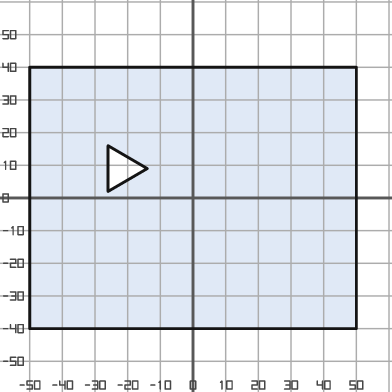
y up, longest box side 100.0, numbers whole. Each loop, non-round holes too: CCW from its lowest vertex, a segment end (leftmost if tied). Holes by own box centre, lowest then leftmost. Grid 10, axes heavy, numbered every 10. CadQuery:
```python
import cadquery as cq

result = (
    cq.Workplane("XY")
    .moveTo(-50.0, -40.0)
    .lineTo(50.0, -40.0)
    .lineTo(50.0, 40.0)
    .lineTo(-50.0, 40.0)
    .close()
    .moveTo(-26.0, 2.0)
    .lineTo(-14.0, 9.0)
    .lineTo(-26.0, 16.0)
    .close()
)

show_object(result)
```